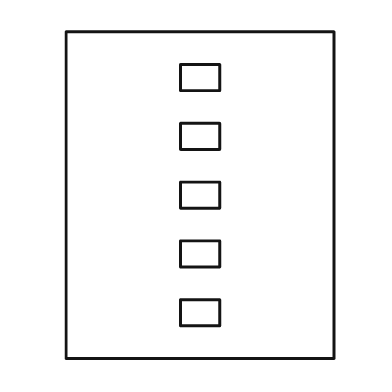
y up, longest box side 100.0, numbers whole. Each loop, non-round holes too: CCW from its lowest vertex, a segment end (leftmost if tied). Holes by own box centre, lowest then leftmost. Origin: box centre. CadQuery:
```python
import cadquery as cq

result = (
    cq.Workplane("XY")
    .moveTo(-41.0, -50.0)
    .lineTo(41.0, -50.0)
    .lineTo(41.0, 50.0)
    .lineTo(-41.0, 50.0)
    .close()
    .moveTo(-6.0, -40.0)
    .lineTo(6.0, -40.0)
    .lineTo(6.0, -32.0)
    .lineTo(-6.0, -32.0)
    .close()
    .moveTo(-6.0, -22.0)
    .lineTo(6.0, -22.0)
    .lineTo(6.0, -14.0)
    .lineTo(-6.0, -14.0)
    .close()
    .moveTo(-6.0, -4.0)
    .lineTo(6.0, -4.0)
    .lineTo(6.0, 4.0)
    .lineTo(-6.0, 4.0)
    .close()
    .moveTo(-6.0, 14.0)
    .lineTo(6.0, 14.0)
    .lineTo(6.0, 22.0)
    .lineTo(-6.0, 22.0)
    .close()
    .moveTo(-6.0, 32.0)
    .lineTo(6.0, 32.0)
    .lineTo(6.0, 40.0)
    .lineTo(-6.0, 40.0)
    .close()
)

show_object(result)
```